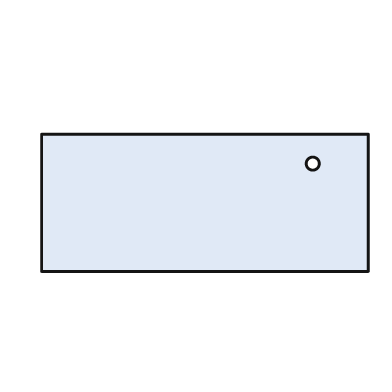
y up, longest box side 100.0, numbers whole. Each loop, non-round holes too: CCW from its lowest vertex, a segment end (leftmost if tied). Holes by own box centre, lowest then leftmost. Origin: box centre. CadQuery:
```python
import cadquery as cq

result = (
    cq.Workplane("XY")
    .moveTo(-50.0, -21.0)
    .lineTo(50.0, -21.0)
    .lineTo(50.0, 21.0)
    .lineTo(-50.0, 21.0)
    .close()
    .moveTo(33.0, 12.0)
    .circle(2.0)
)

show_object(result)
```